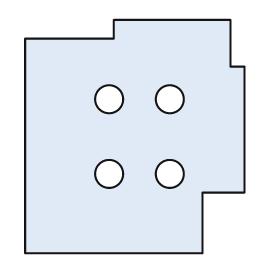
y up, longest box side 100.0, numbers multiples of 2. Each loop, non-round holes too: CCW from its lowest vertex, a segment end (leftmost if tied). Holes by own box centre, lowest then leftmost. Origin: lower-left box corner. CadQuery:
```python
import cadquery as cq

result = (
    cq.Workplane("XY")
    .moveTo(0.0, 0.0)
    .lineTo(76.0, 0.0)
    .lineTo(76.0, 26.0)
    .lineTo(94.0, 26.0)
    .lineTo(94.0, 80.0)
    .lineTo(88.0, 80.0)
    .lineTo(88.0, 100.0)
    .lineTo(38.0, 100.0)
    .lineTo(38.0, 92.0)
    .lineTo(0.0, 92.0)
    .close()
    .moveTo(36.0, 34.0)
    .circle(6.0)
    .moveTo(62.0, 34.0)
    .circle(6.0)
    .moveTo(36.0, 66.0)
    .circle(6.0)
    .moveTo(62.0, 66.0)
    .circle(6.0)
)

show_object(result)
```